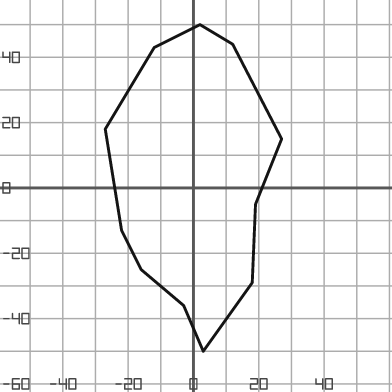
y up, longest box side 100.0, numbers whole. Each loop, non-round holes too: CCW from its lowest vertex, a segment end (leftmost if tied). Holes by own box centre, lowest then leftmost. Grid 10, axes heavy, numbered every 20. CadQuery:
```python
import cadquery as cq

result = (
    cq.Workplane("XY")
    .moveTo(3.0, -50.0)
    .lineTo(18.0, -29.0)
    .lineTo(19.0, -5.0)
    .lineTo(27.0, 15.0)
    .lineTo(12.0, 44.0)
    .lineTo(2.0, 50.0)
    .lineTo(-12.0, 43.0)
    .lineTo(-27.0, 18.0)
    .lineTo(-22.0, -13.0)
    .lineTo(-16.0, -25.0)
    .lineTo(-3.0, -36.0)
    .close()
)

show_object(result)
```